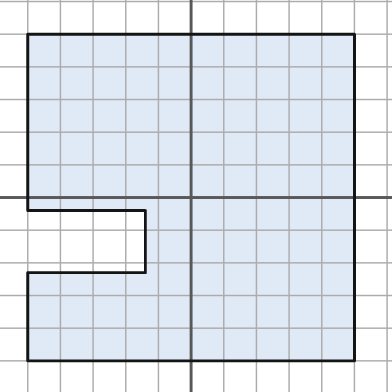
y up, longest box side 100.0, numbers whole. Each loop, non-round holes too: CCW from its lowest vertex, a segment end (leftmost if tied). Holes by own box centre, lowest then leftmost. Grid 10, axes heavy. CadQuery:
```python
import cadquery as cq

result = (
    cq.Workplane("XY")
    .moveTo(-50.0, -50.0)
    .lineTo(50.0, -50.0)
    .lineTo(50.0, 50.0)
    .lineTo(-50.0, 50.0)
    .lineTo(-50.0, -4.0)
    .lineTo(-14.0, -4.0)
    .lineTo(-14.0, -23.0)
    .lineTo(-50.0, -23.0)
    .close()
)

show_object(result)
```